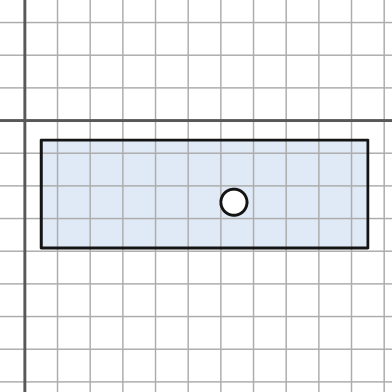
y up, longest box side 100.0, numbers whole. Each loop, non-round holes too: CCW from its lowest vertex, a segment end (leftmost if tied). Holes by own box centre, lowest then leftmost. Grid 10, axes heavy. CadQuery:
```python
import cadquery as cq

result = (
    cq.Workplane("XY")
    .moveTo(5.0, -39.0)
    .lineTo(105.0, -39.0)
    .lineTo(105.0, -6.0)
    .lineTo(5.0, -6.0)
    .close()
    .moveTo(64.0, -25.0)
    .circle(4.0)
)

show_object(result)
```